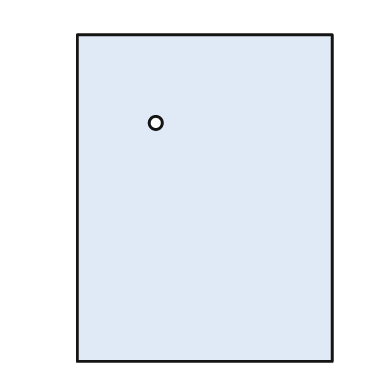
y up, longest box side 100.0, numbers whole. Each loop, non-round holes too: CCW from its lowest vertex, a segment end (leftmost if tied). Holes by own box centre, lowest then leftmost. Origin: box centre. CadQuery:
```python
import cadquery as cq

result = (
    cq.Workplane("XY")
    .moveTo(-39.0, -50.0)
    .lineTo(39.0, -50.0)
    .lineTo(39.0, 50.0)
    .lineTo(-39.0, 50.0)
    .close()
    .moveTo(-15.0, 23.0)
    .circle(2.0)
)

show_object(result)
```